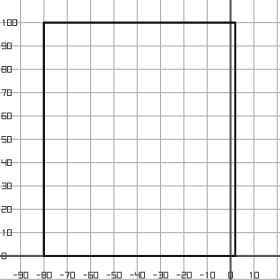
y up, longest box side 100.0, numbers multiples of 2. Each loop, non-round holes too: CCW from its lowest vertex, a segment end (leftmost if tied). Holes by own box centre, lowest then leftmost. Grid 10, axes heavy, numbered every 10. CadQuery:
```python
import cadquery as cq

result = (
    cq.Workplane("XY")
    .moveTo(-80.0, 0.0)
    .lineTo(2.0, 0.0)
    .lineTo(2.0, 100.0)
    .lineTo(-80.0, 100.0)
    .close()
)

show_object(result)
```